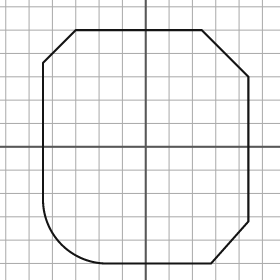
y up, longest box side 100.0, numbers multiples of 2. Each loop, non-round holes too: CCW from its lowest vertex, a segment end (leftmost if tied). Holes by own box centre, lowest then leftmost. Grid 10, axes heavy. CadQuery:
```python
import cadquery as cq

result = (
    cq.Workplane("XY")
    .moveTo(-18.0, -50.0)
    .lineTo(28.0, -50.0)
    .lineTo(44.0, -32.0)
    .lineTo(44.0, 30.0)
    .lineTo(24.0, 50.0)
    .lineTo(-30.0, 50.0)
    .lineTo(-44.0, 36.0)
    .lineTo(-44.0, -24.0)
    .threePointArc((-36.0, -42.0), (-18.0, -50.0))
    .close()
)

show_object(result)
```